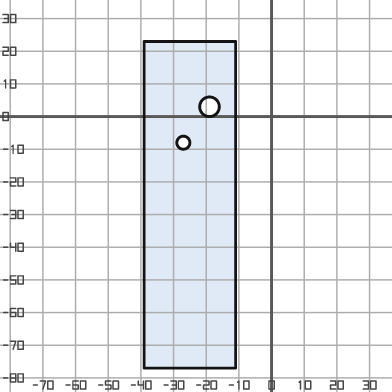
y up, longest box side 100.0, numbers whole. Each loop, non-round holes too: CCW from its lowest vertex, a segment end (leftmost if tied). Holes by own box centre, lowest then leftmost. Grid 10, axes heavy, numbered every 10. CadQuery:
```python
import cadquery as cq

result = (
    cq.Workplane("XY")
    .moveTo(-39.0, -77.0)
    .lineTo(-11.0, -77.0)
    .lineTo(-11.0, 23.0)
    .lineTo(-39.0, 23.0)
    .close()
    .moveTo(-27.0, -8.0)
    .circle(2.0)
    .moveTo(-19.0, 3.0)
    .circle(3.0)
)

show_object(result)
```